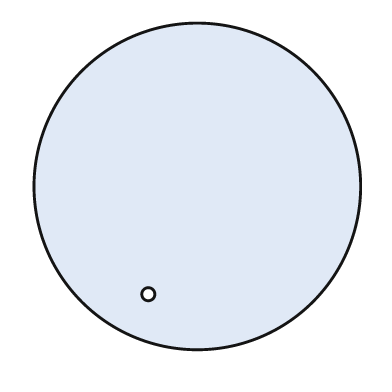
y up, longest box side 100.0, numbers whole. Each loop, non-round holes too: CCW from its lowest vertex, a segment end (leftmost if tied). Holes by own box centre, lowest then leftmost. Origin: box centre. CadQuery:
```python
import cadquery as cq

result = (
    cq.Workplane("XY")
    .moveTo(0.0, 0.0)
    .circle(50.0)
    .moveTo(-15.0, -33.0)
    .circle(2.0)
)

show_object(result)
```